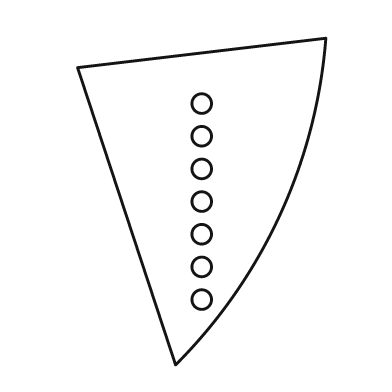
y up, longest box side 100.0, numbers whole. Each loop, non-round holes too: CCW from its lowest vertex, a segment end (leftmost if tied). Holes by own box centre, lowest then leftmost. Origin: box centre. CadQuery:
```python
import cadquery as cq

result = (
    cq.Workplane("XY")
    .moveTo(-8.0, -50.0)
    .threePointArc((24.0, -4.0), (38.0, 50.0))
    .lineTo(-38.0, 41.0)
    .close()
    .moveTo(0.0, -30.0)
    .circle(3.0)
    .moveTo(0.0, -20.0)
    .circle(3.0)
    .moveTo(0.0, -10.0)
    .circle(3.0)
    .moveTo(0.0, 0.0)
    .circle(3.0)
    .moveTo(0.0, 10.0)
    .circle(3.0)
    .moveTo(0.0, 20.0)
    .circle(3.0)
    .moveTo(0.0, 30.0)
    .circle(3.0)
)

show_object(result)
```